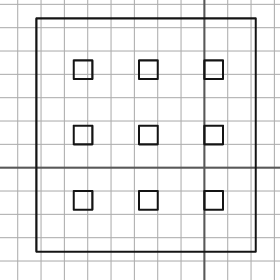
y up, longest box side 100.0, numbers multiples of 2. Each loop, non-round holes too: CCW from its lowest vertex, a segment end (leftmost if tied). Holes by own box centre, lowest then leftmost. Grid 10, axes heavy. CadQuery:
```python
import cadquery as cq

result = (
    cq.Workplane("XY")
    .moveTo(-72.0, -36.0)
    .lineTo(22.0, -36.0)
    .lineTo(22.0, 64.0)
    .lineTo(-72.0, 64.0)
    .close()
    .moveTo(-56.0, -18.0)
    .lineTo(-48.0, -18.0)
    .lineTo(-48.0, -10.0)
    .lineTo(-56.0, -10.0)
    .close()
    .moveTo(-28.0, -18.0)
    .lineTo(-20.0, -18.0)
    .lineTo(-20.0, -10.0)
    .lineTo(-28.0, -10.0)
    .close()
    .moveTo(0.0, -18.0)
    .lineTo(8.0, -18.0)
    .lineTo(8.0, -10.0)
    .lineTo(0.0, -10.0)
    .close()
    .moveTo(-56.0, 10.0)
    .lineTo(-48.0, 10.0)
    .lineTo(-48.0, 18.0)
    .lineTo(-56.0, 18.0)
    .close()
    .moveTo(-28.0, 10.0)
    .lineTo(-20.0, 10.0)
    .lineTo(-20.0, 18.0)
    .lineTo(-28.0, 18.0)
    .close()
    .moveTo(0.0, 10.0)
    .lineTo(8.0, 10.0)
    .lineTo(8.0, 18.0)
    .lineTo(0.0, 18.0)
    .close()
    .moveTo(-56.0, 38.0)
    .lineTo(-48.0, 38.0)
    .lineTo(-48.0, 46.0)
    .lineTo(-56.0, 46.0)
    .close()
    .moveTo(-28.0, 38.0)
    .lineTo(-20.0, 38.0)
    .lineTo(-20.0, 46.0)
    .lineTo(-28.0, 46.0)
    .close()
    .moveTo(0.0, 38.0)
    .lineTo(8.0, 38.0)
    .lineTo(8.0, 46.0)
    .lineTo(0.0, 46.0)
    .close()
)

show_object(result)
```